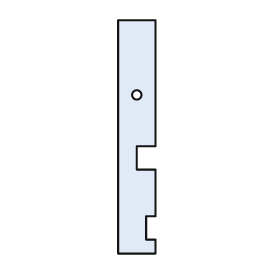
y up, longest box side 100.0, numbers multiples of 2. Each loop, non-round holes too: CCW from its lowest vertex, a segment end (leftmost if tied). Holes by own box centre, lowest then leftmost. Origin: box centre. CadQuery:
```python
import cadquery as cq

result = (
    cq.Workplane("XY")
    .moveTo(-8.0, -50.0)
    .lineTo(8.0, -50.0)
    .lineTo(8.0, -44.0)
    .lineTo(4.0, -44.0)
    .lineTo(4.0, -34.0)
    .lineTo(8.0, -34.0)
    .lineTo(8.0, -14.0)
    .lineTo(0.0, -14.0)
    .lineTo(0.0, -4.0)
    .lineTo(8.0, -4.0)
    .lineTo(8.0, 50.0)
    .lineTo(-8.0, 50.0)
    .close()
    .moveTo(0.0, 18.0)
    .circle(2.0)
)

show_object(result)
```